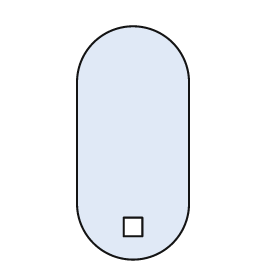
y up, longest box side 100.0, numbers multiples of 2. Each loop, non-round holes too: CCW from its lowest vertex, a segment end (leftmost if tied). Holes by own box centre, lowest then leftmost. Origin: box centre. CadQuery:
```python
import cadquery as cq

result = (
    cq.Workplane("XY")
    .moveTo(-24.0, -26.0)
    .threePointArc((0.0, -50.0), (24.0, -26.0))
    .lineTo(24.0, 26.0)
    .threePointArc((0.0, 50.0), (-24.0, 26.0))
    .close()
    .moveTo(-4.0, -40.0)
    .lineTo(4.0, -40.0)
    .lineTo(4.0, -32.0)
    .lineTo(-4.0, -32.0)
    .close()
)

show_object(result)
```